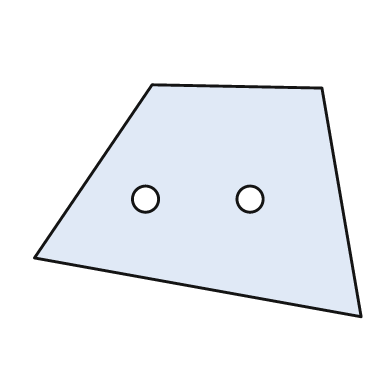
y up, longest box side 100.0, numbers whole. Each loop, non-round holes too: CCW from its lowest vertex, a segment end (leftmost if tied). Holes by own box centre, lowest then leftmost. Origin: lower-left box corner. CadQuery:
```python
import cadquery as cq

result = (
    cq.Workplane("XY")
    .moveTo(100.0, 0.0)
    .lineTo(88.0, 70.0)
    .lineTo(36.0, 71.0)
    .lineTo(0.0, 18.0)
    .close()
    .moveTo(34.0, 36.0)
    .circle(4.0)
    .moveTo(66.0, 36.0)
    .circle(4.0)
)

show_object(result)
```